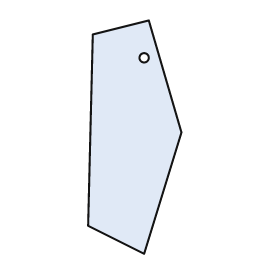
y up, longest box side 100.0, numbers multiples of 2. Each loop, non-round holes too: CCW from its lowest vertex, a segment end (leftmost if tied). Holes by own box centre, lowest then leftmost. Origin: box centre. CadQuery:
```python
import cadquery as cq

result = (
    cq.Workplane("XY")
    .moveTo(4.0, -50.0)
    .lineTo(20.0, 2.0)
    .lineTo(6.0, 50.0)
    .lineTo(-18.0, 44.0)
    .lineTo(-20.0, -38.0)
    .close()
    .moveTo(4.0, 34.0)
    .circle(2.0)
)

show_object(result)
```